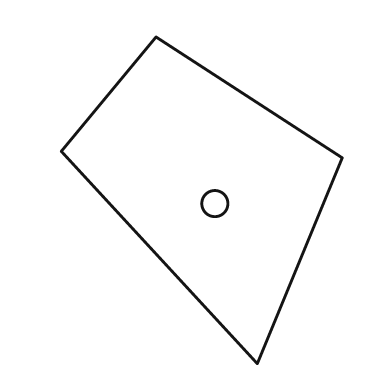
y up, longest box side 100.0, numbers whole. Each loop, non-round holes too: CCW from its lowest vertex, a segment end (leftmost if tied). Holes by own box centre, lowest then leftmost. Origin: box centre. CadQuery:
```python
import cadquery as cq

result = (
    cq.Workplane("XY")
    .moveTo(17.0, -50.0)
    .lineTo(43.0, 13.0)
    .lineTo(-14.0, 50.0)
    .lineTo(-43.0, 15.0)
    .close()
    .moveTo(4.0, -1.0)
    .circle(4.0)
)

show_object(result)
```